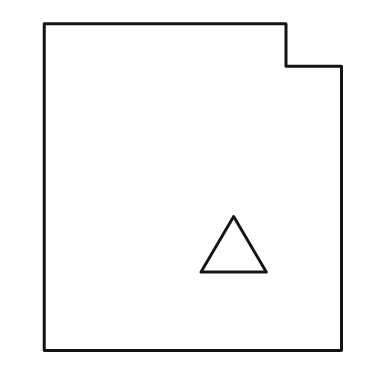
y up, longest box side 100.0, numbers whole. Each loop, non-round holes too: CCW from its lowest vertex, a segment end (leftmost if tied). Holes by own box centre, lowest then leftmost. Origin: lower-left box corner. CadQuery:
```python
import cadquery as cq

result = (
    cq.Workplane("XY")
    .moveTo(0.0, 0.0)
    .lineTo(91.0, 0.0)
    .lineTo(91.0, 87.0)
    .lineTo(74.0, 87.0)
    .lineTo(74.0, 100.0)
    .lineTo(0.0, 100.0)
    .close()
    .moveTo(48.0, 24.0)
    .lineTo(68.0, 24.0)
    .lineTo(58.0, 41.0)
    .close()
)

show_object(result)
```